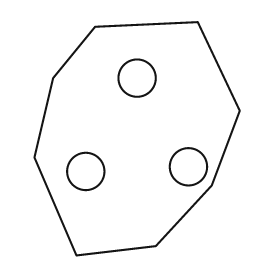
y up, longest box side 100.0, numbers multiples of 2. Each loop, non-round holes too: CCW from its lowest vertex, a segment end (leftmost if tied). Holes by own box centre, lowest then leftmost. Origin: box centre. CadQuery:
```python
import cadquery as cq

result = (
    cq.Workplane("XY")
    .moveTo(-26.0, -50.0)
    .lineTo(8.0, -46.0)
    .lineTo(32.0, -20.0)
    .lineTo(44.0, 12.0)
    .lineTo(26.0, 50.0)
    .lineTo(-18.0, 48.0)
    .lineTo(-36.0, 26.0)
    .lineTo(-44.0, -8.0)
    .close()
    .moveTo(-22.0, -14.0)
    .circle(8.0)
    .moveTo(22.0, -12.0)
    .circle(8.0)
    .moveTo(0.0, 26.0)
    .circle(8.0)
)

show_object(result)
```